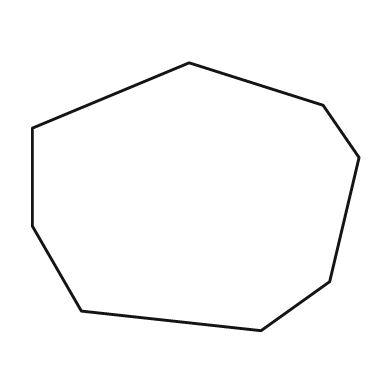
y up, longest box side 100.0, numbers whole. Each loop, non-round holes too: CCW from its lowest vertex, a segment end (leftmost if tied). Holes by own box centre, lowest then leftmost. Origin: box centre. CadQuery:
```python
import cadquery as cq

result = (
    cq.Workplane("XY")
    .moveTo(20.0, -41.0)
    .lineTo(41.0, -26.0)
    .lineTo(50.0, 12.0)
    .lineTo(39.0, 28.0)
    .lineTo(-2.0, 41.0)
    .lineTo(-50.0, 21.0)
    .lineTo(-50.0, -9.0)
    .lineTo(-35.0, -35.0)
    .close()
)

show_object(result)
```